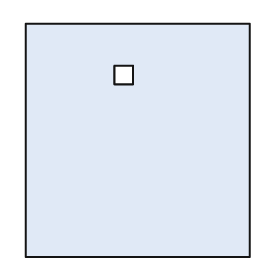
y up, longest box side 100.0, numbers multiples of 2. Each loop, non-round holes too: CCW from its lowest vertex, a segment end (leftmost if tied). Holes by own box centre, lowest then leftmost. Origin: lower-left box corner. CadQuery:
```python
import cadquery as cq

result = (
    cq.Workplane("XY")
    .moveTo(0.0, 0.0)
    .lineTo(96.0, 0.0)
    .lineTo(96.0, 100.0)
    .lineTo(0.0, 100.0)
    .close()
    .moveTo(38.0, 74.0)
    .lineTo(46.0, 74.0)
    .lineTo(46.0, 82.0)
    .lineTo(38.0, 82.0)
    .close()
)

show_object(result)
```